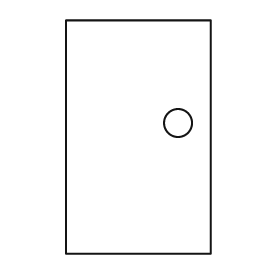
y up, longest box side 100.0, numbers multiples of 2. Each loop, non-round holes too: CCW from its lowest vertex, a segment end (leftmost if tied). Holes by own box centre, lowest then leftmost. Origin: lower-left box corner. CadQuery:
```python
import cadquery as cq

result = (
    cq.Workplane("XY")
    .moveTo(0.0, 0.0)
    .lineTo(62.0, 0.0)
    .lineTo(62.0, 100.0)
    .lineTo(0.0, 100.0)
    .close()
    .moveTo(48.0, 56.0)
    .circle(6.0)
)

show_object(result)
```